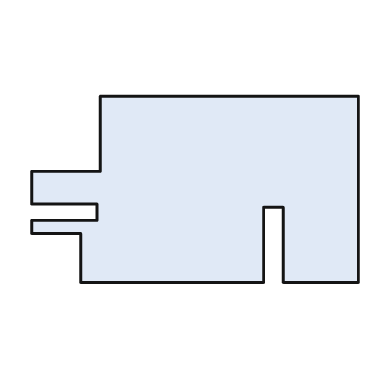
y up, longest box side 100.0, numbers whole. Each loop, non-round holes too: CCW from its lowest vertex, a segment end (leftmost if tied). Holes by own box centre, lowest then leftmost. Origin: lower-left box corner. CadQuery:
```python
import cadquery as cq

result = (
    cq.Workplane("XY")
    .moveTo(15.0, 0.0)
    .lineTo(71.0, 0.0)
    .lineTo(71.0, 23.0)
    .lineTo(77.0, 23.0)
    .lineTo(77.0, 0.0)
    .lineTo(100.0, 0.0)
    .lineTo(100.0, 57.0)
    .lineTo(21.0, 57.0)
    .lineTo(21.0, 34.0)
    .lineTo(0.0, 34.0)
    .lineTo(0.0, 24.0)
    .lineTo(20.0, 24.0)
    .lineTo(20.0, 19.0)
    .lineTo(0.0, 19.0)
    .lineTo(0.0, 15.0)
    .lineTo(15.0, 15.0)
    .close()
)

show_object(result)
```